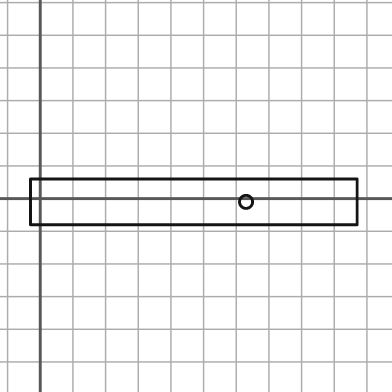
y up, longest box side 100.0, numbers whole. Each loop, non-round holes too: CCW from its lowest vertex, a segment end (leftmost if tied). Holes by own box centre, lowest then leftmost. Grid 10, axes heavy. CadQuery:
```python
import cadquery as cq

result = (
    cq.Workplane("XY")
    .moveTo(-3.0, -8.0)
    .lineTo(97.0, -8.0)
    .lineTo(97.0, 6.0)
    .lineTo(-3.0, 6.0)
    .close()
    .moveTo(63.0, -1.0)
    .circle(2.0)
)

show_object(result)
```